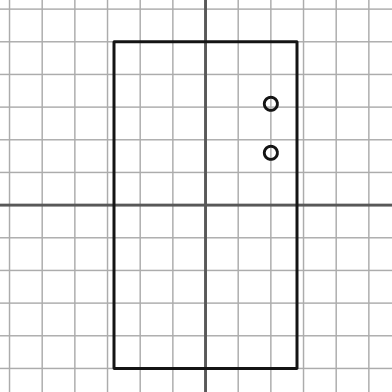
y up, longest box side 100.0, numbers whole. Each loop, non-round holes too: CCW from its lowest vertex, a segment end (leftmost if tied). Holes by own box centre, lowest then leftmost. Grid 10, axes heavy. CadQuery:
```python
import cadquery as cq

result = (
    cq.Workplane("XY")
    .moveTo(-28.0, -50.0)
    .lineTo(28.0, -50.0)
    .lineTo(28.0, 50.0)
    .lineTo(-28.0, 50.0)
    .close()
    .moveTo(20.0, 16.0)
    .circle(2.0)
    .moveTo(20.0, 31.0)
    .circle(2.0)
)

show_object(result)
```